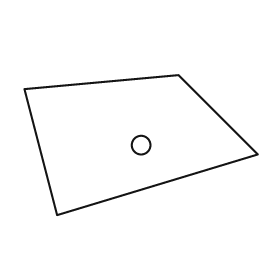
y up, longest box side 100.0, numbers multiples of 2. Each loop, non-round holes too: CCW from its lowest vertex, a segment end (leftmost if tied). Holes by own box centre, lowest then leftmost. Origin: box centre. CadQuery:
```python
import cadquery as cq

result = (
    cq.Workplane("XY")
    .moveTo(-36.0, -30.0)
    .lineTo(50.0, -4.0)
    .lineTo(16.0, 30.0)
    .lineTo(-50.0, 24.0)
    .close()
    .moveTo(0.0, 0.0)
    .circle(4.0)
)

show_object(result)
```